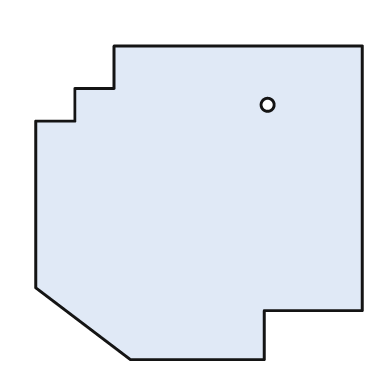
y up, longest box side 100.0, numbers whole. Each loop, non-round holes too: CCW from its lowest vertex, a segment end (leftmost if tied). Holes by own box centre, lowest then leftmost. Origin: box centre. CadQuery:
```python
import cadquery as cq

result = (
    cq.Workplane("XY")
    .moveTo(-21.0, -48.0)
    .lineTo(20.0, -48.0)
    .lineTo(20.0, -33.0)
    .lineTo(50.0, -33.0)
    .lineTo(50.0, 48.0)
    .lineTo(-26.0, 48.0)
    .lineTo(-26.0, 35.0)
    .lineTo(-38.0, 35.0)
    .lineTo(-38.0, 25.0)
    .lineTo(-50.0, 25.0)
    .lineTo(-50.0, -26.0)
    .close()
    .moveTo(21.0, 30.0)
    .circle(2.0)
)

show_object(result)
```